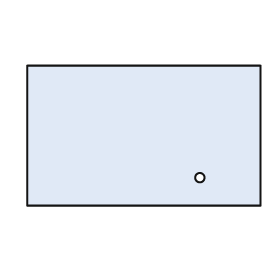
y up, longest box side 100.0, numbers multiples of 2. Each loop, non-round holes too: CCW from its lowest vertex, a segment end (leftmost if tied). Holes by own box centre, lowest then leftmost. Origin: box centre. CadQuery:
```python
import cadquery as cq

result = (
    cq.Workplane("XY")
    .moveTo(-50.0, -30.0)
    .lineTo(50.0, -30.0)
    .lineTo(50.0, 30.0)
    .lineTo(-50.0, 30.0)
    .close()
    .moveTo(24.0, -18.0)
    .circle(2.0)
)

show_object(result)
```